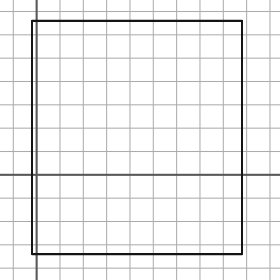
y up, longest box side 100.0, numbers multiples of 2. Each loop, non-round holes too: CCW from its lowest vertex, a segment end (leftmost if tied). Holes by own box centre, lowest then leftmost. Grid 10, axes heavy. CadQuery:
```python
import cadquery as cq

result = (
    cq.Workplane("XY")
    .moveTo(-2.0, -34.0)
    .lineTo(88.0, -34.0)
    .lineTo(88.0, 66.0)
    .lineTo(-2.0, 66.0)
    .close()
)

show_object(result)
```